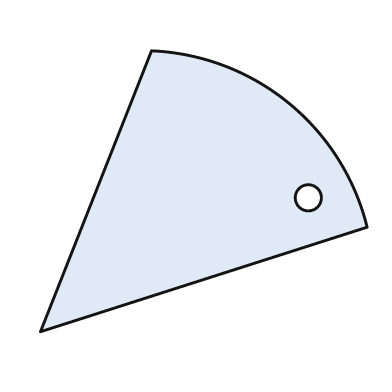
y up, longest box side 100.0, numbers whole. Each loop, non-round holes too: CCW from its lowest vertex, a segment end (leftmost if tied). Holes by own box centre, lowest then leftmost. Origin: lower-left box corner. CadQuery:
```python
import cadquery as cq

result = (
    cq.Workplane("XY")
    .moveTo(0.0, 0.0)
    .lineTo(100.0, 32.0)
    .threePointArc((76.0, 70.0), (34.0, 86.0))
    .close()
    .moveTo(82.0, 41.0)
    .circle(4.0)
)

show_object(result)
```